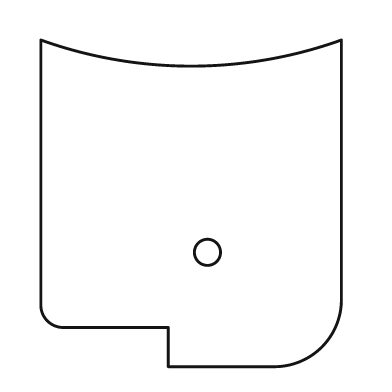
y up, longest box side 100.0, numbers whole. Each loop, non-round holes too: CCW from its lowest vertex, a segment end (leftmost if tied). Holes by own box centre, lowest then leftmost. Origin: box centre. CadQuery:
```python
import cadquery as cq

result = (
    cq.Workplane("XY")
    .moveTo(-7.0, -50.0)
    .lineTo(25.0, -50.0)
    .threePointArc((40.0, -44.0), (46.0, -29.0))
    .lineTo(46.0, 50.0)
    .threePointArc((0.0, 42.0), (-46.0, 50.0))
    .lineTo(-46.0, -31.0)
    .threePointArc((-44.0, -36.0), (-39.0, -38.0))
    .lineTo(-7.0, -38.0)
    .close()
    .moveTo(5.0, -15.0)
    .circle(4.0)
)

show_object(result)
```